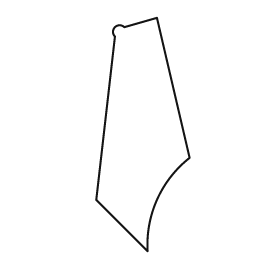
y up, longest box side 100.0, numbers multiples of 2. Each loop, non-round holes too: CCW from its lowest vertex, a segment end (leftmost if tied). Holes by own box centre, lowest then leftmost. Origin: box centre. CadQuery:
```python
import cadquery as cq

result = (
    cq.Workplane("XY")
    .moveTo(2.0, -50.0)
    .threePointArc((6.0, -28.0), (20.0, -10.0))
    .lineTo(6.0, 50.0)
    .lineTo(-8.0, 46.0)
    .threePointArc((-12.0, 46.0), (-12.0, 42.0))
    .lineTo(-20.0, -28.0)
    .close()
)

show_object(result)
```